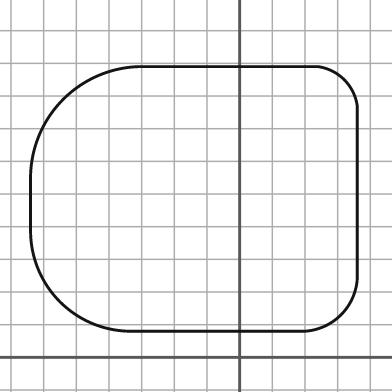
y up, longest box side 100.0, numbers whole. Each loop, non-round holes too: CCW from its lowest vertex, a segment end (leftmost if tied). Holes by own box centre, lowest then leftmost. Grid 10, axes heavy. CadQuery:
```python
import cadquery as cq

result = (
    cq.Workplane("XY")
    .moveTo(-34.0, 8.0)
    .lineTo(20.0, 8.0)
    .threePointArc((31.0, 13.0), (36.0, 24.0))
    .lineTo(36.0, 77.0)
    .threePointArc((32.0, 85.0), (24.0, 89.0))
    .lineTo(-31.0, 89.0)
    .threePointArc((-54.0, 79.0), (-64.0, 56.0))
    .lineTo(-64.0, 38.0)
    .threePointArc((-55.0, 17.0), (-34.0, 8.0))
    .close()
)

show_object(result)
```